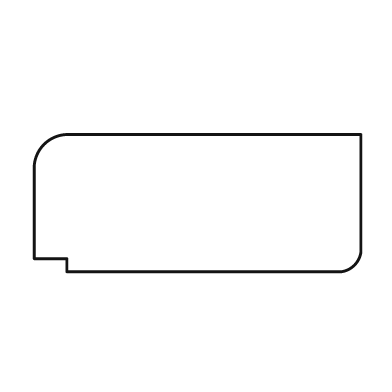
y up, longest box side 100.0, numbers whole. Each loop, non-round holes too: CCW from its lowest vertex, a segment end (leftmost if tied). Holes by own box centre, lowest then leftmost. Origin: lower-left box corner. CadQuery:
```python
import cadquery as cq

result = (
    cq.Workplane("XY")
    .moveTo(10.0, 0.0)
    .lineTo(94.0, 0.0)
    .threePointArc((98.0, 2.0), (100.0, 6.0))
    .lineTo(100.0, 42.0)
    .lineTo(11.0, 42.0)
    .threePointArc((3.0, 39.0), (0.0, 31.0))
    .lineTo(0.0, 4.0)
    .lineTo(10.0, 4.0)
    .close()
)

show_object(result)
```